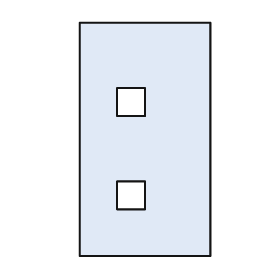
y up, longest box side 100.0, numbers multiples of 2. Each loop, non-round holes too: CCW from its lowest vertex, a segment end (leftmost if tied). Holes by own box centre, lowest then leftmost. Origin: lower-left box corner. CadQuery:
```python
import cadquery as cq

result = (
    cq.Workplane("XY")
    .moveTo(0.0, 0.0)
    .lineTo(56.0, 0.0)
    .lineTo(56.0, 100.0)
    .lineTo(0.0, 100.0)
    .close()
    .moveTo(16.0, 20.0)
    .lineTo(28.0, 20.0)
    .lineTo(28.0, 32.0)
    .lineTo(16.0, 32.0)
    .close()
    .moveTo(16.0, 60.0)
    .lineTo(28.0, 60.0)
    .lineTo(28.0, 72.0)
    .lineTo(16.0, 72.0)
    .close()
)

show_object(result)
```